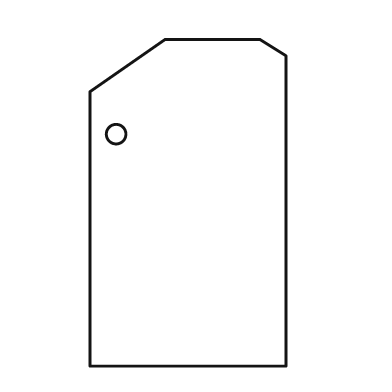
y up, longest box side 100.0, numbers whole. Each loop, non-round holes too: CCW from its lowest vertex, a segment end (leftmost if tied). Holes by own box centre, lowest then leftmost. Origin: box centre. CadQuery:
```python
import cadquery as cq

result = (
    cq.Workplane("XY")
    .moveTo(-30.0, -50.0)
    .lineTo(30.0, -50.0)
    .lineTo(30.0, 45.0)
    .lineTo(22.0, 50.0)
    .lineTo(-7.0, 50.0)
    .lineTo(-30.0, 34.0)
    .close()
    .moveTo(-22.0, 21.0)
    .circle(3.0)
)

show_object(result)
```